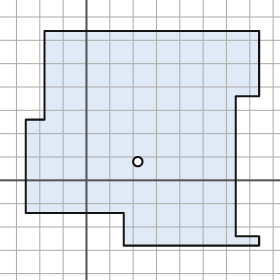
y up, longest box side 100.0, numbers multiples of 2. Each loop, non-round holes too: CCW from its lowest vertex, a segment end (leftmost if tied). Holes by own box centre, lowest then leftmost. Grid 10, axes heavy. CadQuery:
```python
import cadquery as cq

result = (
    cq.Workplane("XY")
    .moveTo(16.0, -28.0)
    .lineTo(74.0, -28.0)
    .lineTo(74.0, -24.0)
    .lineTo(64.0, -24.0)
    .lineTo(64.0, 36.0)
    .lineTo(74.0, 36.0)
    .lineTo(74.0, 64.0)
    .lineTo(-18.0, 64.0)
    .lineTo(-18.0, 26.0)
    .lineTo(-26.0, 26.0)
    .lineTo(-26.0, -14.0)
    .lineTo(16.0, -14.0)
    .close()
    .moveTo(22.0, 8.0)
    .circle(2.0)
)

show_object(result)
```